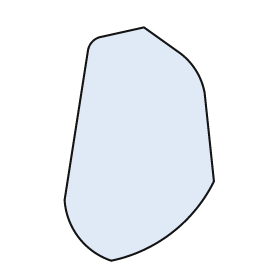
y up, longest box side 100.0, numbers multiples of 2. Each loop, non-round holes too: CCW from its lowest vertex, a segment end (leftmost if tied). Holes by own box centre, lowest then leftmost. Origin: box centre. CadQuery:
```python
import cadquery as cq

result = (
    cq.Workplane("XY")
    .moveTo(-12.0, -50.0)
    .threePointArc((14.0, -38.0), (32.0, -16.0))
    .lineTo(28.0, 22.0)
    .threePointArc((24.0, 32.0), (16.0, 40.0))
    .lineTo(2.0, 50.0)
    .lineTo(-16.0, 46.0)
    .threePointArc((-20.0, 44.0), (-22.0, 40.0))
    .lineTo(-32.0, -24.0)
    .threePointArc((-26.0, -40.0), (-12.0, -50.0))
    .close()
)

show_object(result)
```